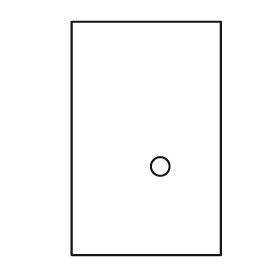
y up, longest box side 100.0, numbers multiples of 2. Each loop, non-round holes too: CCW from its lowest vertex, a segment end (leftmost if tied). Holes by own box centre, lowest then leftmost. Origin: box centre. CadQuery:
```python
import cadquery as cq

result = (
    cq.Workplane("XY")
    .moveTo(-32.0, -50.0)
    .lineTo(32.0, -50.0)
    .lineTo(32.0, 50.0)
    .lineTo(-32.0, 50.0)
    .close()
    .moveTo(6.0, -12.0)
    .circle(4.0)
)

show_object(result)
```